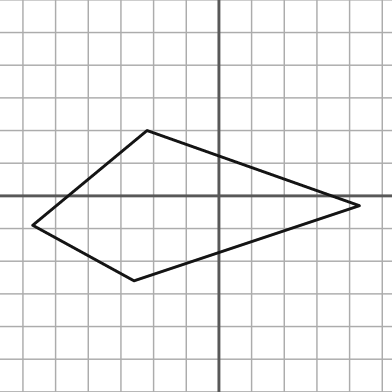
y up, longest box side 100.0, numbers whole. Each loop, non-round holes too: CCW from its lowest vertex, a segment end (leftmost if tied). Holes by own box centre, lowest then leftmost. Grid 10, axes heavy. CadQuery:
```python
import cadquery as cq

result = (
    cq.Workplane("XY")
    .moveTo(-26.0, -26.0)
    .lineTo(43.0, -3.0)
    .lineTo(-22.0, 20.0)
    .lineTo(-57.0, -9.0)
    .close()
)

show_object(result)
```